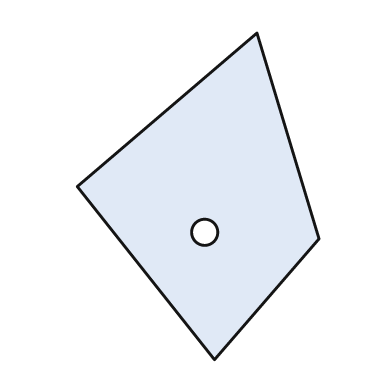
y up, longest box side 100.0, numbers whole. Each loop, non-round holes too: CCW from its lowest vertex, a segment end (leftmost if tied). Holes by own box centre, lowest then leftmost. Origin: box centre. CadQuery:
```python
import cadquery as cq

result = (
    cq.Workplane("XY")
    .moveTo(5.0, -50.0)
    .lineTo(37.0, -13.0)
    .lineTo(18.0, 50.0)
    .lineTo(-37.0, 3.0)
    .close()
    .moveTo(2.0, -11.0)
    .circle(4.0)
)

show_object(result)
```